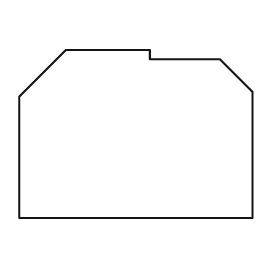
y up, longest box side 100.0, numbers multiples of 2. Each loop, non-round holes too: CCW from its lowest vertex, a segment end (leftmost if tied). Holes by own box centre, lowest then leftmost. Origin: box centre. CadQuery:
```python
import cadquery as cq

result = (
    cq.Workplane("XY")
    .moveTo(-50.0, -36.0)
    .lineTo(50.0, -36.0)
    .lineTo(50.0, 18.0)
    .lineTo(36.0, 32.0)
    .lineTo(6.0, 32.0)
    .lineTo(6.0, 36.0)
    .lineTo(-30.0, 36.0)
    .lineTo(-50.0, 16.0)
    .close()
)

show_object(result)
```